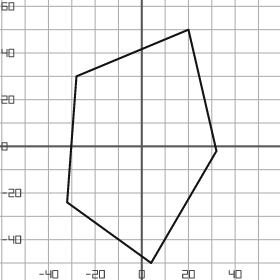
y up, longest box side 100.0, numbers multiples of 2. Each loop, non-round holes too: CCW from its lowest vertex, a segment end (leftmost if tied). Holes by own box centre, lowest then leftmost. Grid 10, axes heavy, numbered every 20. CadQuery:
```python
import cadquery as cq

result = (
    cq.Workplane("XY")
    .moveTo(4.0, -50.0)
    .lineTo(32.0, -2.0)
    .lineTo(20.0, 50.0)
    .lineTo(-28.0, 30.0)
    .lineTo(-32.0, -24.0)
    .close()
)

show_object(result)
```